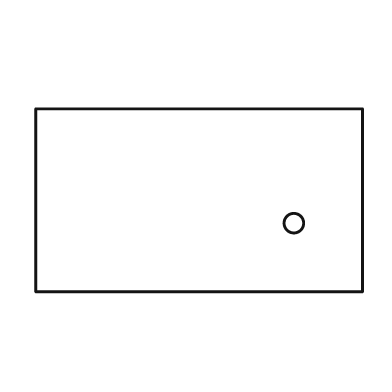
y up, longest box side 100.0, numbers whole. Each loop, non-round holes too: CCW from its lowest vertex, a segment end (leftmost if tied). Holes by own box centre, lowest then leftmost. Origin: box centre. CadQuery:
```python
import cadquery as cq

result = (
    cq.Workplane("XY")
    .moveTo(-50.0, -28.0)
    .lineTo(50.0, -28.0)
    .lineTo(50.0, 28.0)
    .lineTo(-50.0, 28.0)
    .close()
    .moveTo(29.0, -7.0)
    .circle(3.0)
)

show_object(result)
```